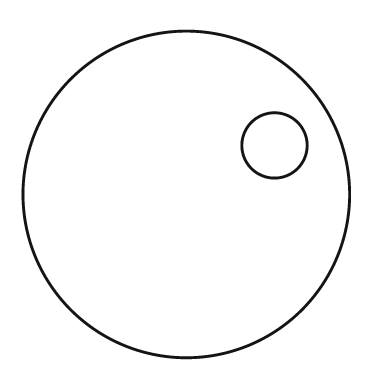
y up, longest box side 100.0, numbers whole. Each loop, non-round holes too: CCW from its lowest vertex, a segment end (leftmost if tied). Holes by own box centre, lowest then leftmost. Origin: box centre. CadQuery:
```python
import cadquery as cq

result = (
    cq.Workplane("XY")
    .moveTo(0.0, 0.0)
    .circle(50.0)
    .moveTo(27.0, 15.0)
    .circle(10.0)
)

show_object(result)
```